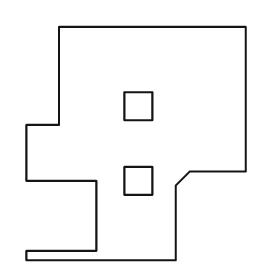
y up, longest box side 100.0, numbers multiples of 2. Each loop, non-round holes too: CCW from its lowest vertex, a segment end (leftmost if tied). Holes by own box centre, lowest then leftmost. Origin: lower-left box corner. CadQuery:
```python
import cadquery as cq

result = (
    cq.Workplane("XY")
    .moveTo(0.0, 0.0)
    .lineTo(64.0, 0.0)
    .lineTo(64.0, 32.0)
    .lineTo(70.0, 38.0)
    .lineTo(94.0, 38.0)
    .lineTo(94.0, 100.0)
    .lineTo(14.0, 100.0)
    .lineTo(14.0, 58.0)
    .lineTo(0.0, 58.0)
    .lineTo(0.0, 34.0)
    .lineTo(30.0, 34.0)
    .lineTo(30.0, 4.0)
    .lineTo(0.0, 4.0)
    .close()
    .moveTo(42.0, 28.0)
    .lineTo(54.0, 28.0)
    .lineTo(54.0, 40.0)
    .lineTo(42.0, 40.0)
    .close()
    .moveTo(42.0, 60.0)
    .lineTo(54.0, 60.0)
    .lineTo(54.0, 72.0)
    .lineTo(42.0, 72.0)
    .close()
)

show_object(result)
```